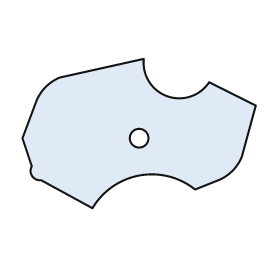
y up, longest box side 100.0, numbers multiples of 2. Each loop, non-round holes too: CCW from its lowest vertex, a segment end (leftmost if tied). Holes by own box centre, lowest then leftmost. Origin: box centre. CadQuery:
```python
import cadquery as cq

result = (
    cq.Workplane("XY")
    .moveTo(-20.0, -32.0)
    .threePointArc((0.0, -18.0), (24.0, -24.0))
    .lineTo(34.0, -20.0)
    .threePointArc((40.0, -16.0), (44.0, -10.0))
    .lineTo(50.0, 12.0)
    .lineTo(30.0, 22.0)
    .threePointArc((12.0, 16.0), (2.0, 32.0))
    .lineTo(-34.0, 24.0)
    .threePointArc((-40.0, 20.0), (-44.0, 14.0))
    .lineTo(-50.0, -2.0)
    .lineTo(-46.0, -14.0)
    .threePointArc((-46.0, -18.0), (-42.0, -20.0))
    .close()
    .moveTo(0.0, -2.0)
    .circle(4.0)
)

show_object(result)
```